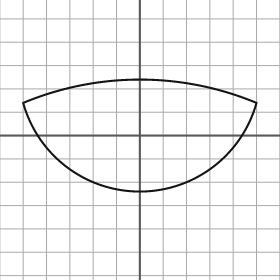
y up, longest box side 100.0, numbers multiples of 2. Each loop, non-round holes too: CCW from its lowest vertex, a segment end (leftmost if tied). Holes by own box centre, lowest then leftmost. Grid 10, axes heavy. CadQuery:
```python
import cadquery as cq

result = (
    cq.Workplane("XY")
    .moveTo(-50.0, 14.0)
    .threePointArc((0.0, -24.0), (50.0, 14.0))
    .threePointArc((0.0, 24.0), (-50.0, 14.0))
    .close()
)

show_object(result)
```